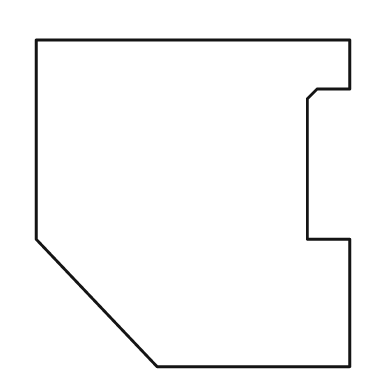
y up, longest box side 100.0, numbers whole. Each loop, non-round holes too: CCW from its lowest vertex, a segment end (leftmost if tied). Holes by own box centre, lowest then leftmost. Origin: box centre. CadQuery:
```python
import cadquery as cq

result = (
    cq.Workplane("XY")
    .moveTo(-11.0, -50.0)
    .lineTo(48.0, -50.0)
    .lineTo(48.0, -11.0)
    .lineTo(35.0, -11.0)
    .lineTo(35.0, 32.0)
    .lineTo(38.0, 35.0)
    .lineTo(48.0, 35.0)
    .lineTo(48.0, 50.0)
    .lineTo(-48.0, 50.0)
    .lineTo(-48.0, -11.0)
    .close()
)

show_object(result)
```